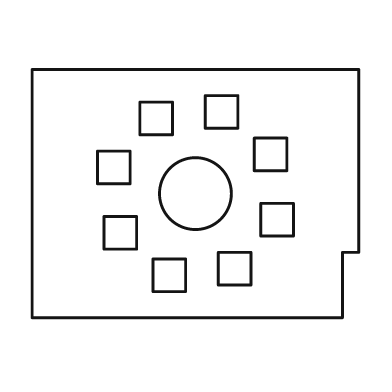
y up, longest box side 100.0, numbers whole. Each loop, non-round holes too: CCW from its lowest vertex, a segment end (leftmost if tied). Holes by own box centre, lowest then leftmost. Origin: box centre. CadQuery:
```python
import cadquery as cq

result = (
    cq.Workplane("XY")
    .moveTo(-50.0, -38.0)
    .lineTo(45.0, -38.0)
    .lineTo(45.0, -18.0)
    .lineTo(50.0, -18.0)
    .lineTo(50.0, 38.0)
    .lineTo(-50.0, 38.0)
    .close()
    .moveTo(-13.0, -30.0)
    .lineTo(-3.0, -30.0)
    .lineTo(-3.0, -20.0)
    .lineTo(-13.0, -20.0)
    .close()
    .moveTo(7.0, -28.0)
    .lineTo(17.0, -28.0)
    .lineTo(17.0, -18.0)
    .lineTo(7.0, -18.0)
    .close()
    .moveTo(-28.0, -17.0)
    .lineTo(-18.0, -17.0)
    .lineTo(-18.0, -7.0)
    .lineTo(-28.0, -7.0)
    .close()
    .moveTo(20.0, -13.0)
    .lineTo(30.0, -13.0)
    .lineTo(30.0, -3.0)
    .lineTo(20.0, -3.0)
    .close()
    .moveTo(0.0, 0.0)
    .circle(11.0)
    .moveTo(-30.0, 3.0)
    .lineTo(-20.0, 3.0)
    .lineTo(-20.0, 13.0)
    .lineTo(-30.0, 13.0)
    .close()
    .moveTo(18.0, 7.0)
    .lineTo(28.0, 7.0)
    .lineTo(28.0, 17.0)
    .lineTo(18.0, 17.0)
    .close()
    .moveTo(-17.0, 18.0)
    .lineTo(-7.0, 18.0)
    .lineTo(-7.0, 28.0)
    .lineTo(-17.0, 28.0)
    .close()
    .moveTo(3.0, 20.0)
    .lineTo(13.0, 20.0)
    .lineTo(13.0, 30.0)
    .lineTo(3.0, 30.0)
    .close()
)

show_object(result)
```